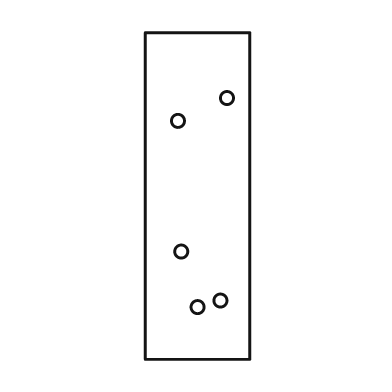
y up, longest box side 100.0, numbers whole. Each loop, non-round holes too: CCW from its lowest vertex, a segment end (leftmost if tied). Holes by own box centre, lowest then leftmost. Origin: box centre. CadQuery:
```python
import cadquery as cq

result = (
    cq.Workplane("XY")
    .moveTo(-16.0, -50.0)
    .lineTo(16.0, -50.0)
    .lineTo(16.0, 50.0)
    .lineTo(-16.0, 50.0)
    .close()
    .moveTo(0.0, -34.0)
    .circle(2.0)
    .moveTo(7.0, -32.0)
    .circle(2.0)
    .moveTo(-5.0, -17.0)
    .circle(2.0)
    .moveTo(-6.0, 23.0)
    .circle(2.0)
    .moveTo(9.0, 30.0)
    .circle(2.0)
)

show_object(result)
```